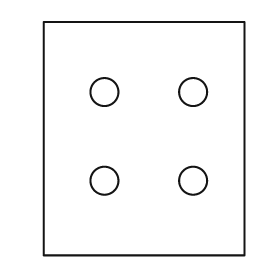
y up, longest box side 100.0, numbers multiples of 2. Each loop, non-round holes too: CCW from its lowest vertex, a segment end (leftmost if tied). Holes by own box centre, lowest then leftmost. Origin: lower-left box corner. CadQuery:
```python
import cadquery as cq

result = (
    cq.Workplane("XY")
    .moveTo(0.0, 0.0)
    .lineTo(86.0, 0.0)
    .lineTo(86.0, 100.0)
    .lineTo(0.0, 100.0)
    .close()
    .moveTo(26.0, 32.0)
    .circle(6.0)
    .moveTo(64.0, 32.0)
    .circle(6.0)
    .moveTo(26.0, 70.0)
    .circle(6.0)
    .moveTo(64.0, 70.0)
    .circle(6.0)
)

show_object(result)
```